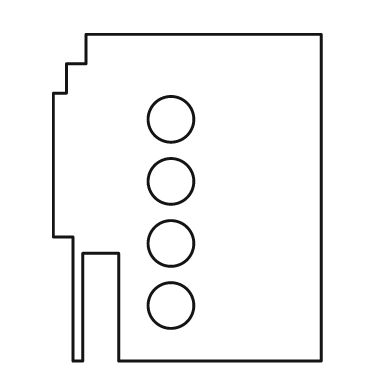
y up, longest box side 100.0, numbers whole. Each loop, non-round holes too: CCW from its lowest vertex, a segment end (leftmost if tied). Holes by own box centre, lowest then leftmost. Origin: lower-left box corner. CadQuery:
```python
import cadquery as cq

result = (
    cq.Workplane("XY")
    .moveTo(6.0, 0.0)
    .lineTo(9.0, 0.0)
    .lineTo(9.0, 33.0)
    .lineTo(20.0, 33.0)
    .lineTo(20.0, 0.0)
    .lineTo(82.0, 0.0)
    .lineTo(82.0, 100.0)
    .lineTo(10.0, 100.0)
    .lineTo(10.0, 91.0)
    .lineTo(4.0, 91.0)
    .lineTo(4.0, 82.0)
    .lineTo(0.0, 82.0)
    .lineTo(0.0, 38.0)
    .lineTo(6.0, 38.0)
    .close()
    .moveTo(36.0, 17.0)
    .circle(7.0)
    .moveTo(36.0, 36.0)
    .circle(7.0)
    .moveTo(36.0, 55.0)
    .circle(7.0)
    .moveTo(36.0, 74.0)
    .circle(7.0)
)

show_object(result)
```